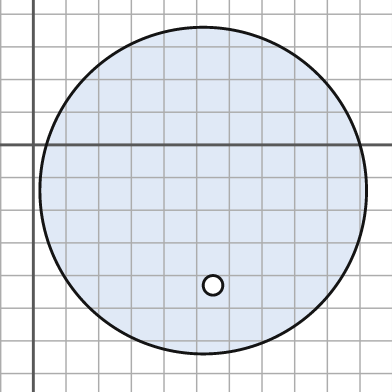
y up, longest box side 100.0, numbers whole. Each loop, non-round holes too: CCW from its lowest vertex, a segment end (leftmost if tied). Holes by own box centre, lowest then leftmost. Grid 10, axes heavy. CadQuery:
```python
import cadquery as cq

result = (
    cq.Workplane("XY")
    .moveTo(52.0, -14.0)
    .circle(50.0)
    .moveTo(55.0, -43.0)
    .circle(3.0)
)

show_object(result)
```